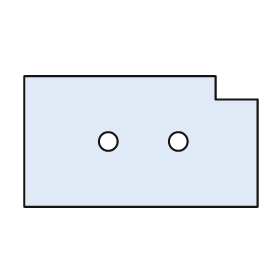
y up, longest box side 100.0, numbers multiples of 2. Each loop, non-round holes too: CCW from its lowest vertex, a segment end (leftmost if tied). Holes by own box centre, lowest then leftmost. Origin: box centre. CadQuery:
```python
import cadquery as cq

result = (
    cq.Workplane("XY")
    .moveTo(-50.0, -28.0)
    .lineTo(50.0, -28.0)
    .lineTo(50.0, 18.0)
    .lineTo(32.0, 18.0)
    .lineTo(32.0, 28.0)
    .lineTo(-50.0, 28.0)
    .close()
    .moveTo(-14.0, 0.0)
    .circle(4.0)
    .moveTo(16.0, 0.0)
    .circle(4.0)
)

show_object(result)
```